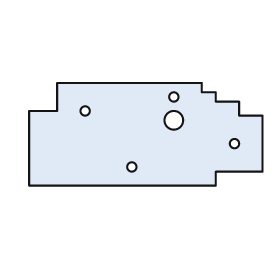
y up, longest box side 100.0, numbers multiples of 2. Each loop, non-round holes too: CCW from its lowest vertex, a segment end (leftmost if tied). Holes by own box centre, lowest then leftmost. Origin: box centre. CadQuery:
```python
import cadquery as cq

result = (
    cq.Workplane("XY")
    .moveTo(-50.0, -22.0)
    .lineTo(30.0, -22.0)
    .lineTo(30.0, -16.0)
    .lineTo(50.0, -16.0)
    .lineTo(50.0, 8.0)
    .lineTo(40.0, 8.0)
    .lineTo(40.0, 14.0)
    .lineTo(30.0, 14.0)
    .lineTo(30.0, 18.0)
    .lineTo(24.0, 18.0)
    .lineTo(24.0, 22.0)
    .lineTo(-38.0, 22.0)
    .lineTo(-38.0, 10.0)
    .lineTo(-50.0, 10.0)
    .close()
    .moveTo(-6.0, -14.0)
    .circle(2.0)
    .moveTo(38.0, -4.0)
    .circle(2.0)
    .moveTo(12.0, 6.0)
    .circle(4.0)
    .moveTo(-26.0, 10.0)
    .circle(2.0)
    .moveTo(12.0, 16.0)
    .circle(2.0)
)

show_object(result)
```